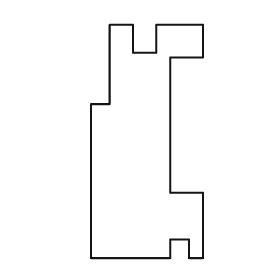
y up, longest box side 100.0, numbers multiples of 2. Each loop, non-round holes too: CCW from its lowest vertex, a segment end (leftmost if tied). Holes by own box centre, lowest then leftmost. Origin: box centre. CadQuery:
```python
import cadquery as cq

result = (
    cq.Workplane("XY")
    .moveTo(-24.0, -50.0)
    .lineTo(10.0, -50.0)
    .lineTo(10.0, -42.0)
    .lineTo(18.0, -42.0)
    .lineTo(18.0, -50.0)
    .lineTo(24.0, -50.0)
    .lineTo(24.0, -22.0)
    .lineTo(10.0, -22.0)
    .lineTo(10.0, 36.0)
    .lineTo(24.0, 36.0)
    .lineTo(24.0, 50.0)
    .lineTo(4.0, 50.0)
    .lineTo(4.0, 38.0)
    .lineTo(-6.0, 38.0)
    .lineTo(-6.0, 50.0)
    .lineTo(-16.0, 50.0)
    .lineTo(-16.0, 16.0)
    .lineTo(-24.0, 16.0)
    .close()
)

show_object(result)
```